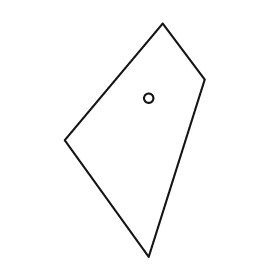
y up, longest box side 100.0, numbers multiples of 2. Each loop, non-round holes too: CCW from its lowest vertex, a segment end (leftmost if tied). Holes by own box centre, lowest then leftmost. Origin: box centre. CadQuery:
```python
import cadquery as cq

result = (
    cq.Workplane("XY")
    .moveTo(6.0, -50.0)
    .lineTo(30.0, 26.0)
    .lineTo(12.0, 50.0)
    .lineTo(-30.0, 0.0)
    .close()
    .moveTo(6.0, 18.0)
    .circle(2.0)
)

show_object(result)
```